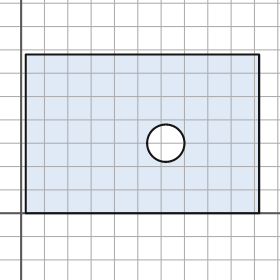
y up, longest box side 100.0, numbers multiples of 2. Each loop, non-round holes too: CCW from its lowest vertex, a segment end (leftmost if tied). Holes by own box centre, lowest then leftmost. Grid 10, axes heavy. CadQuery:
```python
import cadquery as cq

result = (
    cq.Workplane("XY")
    .moveTo(2.0, 0.0)
    .lineTo(102.0, 0.0)
    .lineTo(102.0, 68.0)
    .lineTo(2.0, 68.0)
    .close()
    .moveTo(62.0, 30.0)
    .circle(8.0)
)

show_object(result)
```